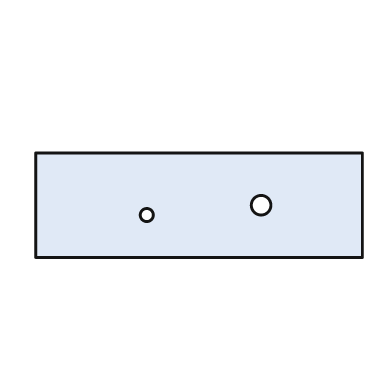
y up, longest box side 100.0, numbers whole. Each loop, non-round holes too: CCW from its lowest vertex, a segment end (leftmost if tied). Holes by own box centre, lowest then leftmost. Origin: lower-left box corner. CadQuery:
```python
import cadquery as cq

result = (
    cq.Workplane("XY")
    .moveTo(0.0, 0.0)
    .lineTo(100.0, 0.0)
    .lineTo(100.0, 32.0)
    .lineTo(0.0, 32.0)
    .close()
    .moveTo(34.0, 13.0)
    .circle(2.0)
    .moveTo(69.0, 16.0)
    .circle(3.0)
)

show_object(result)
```